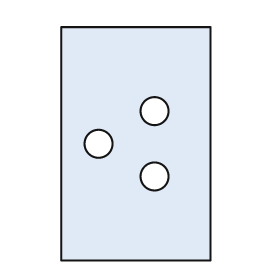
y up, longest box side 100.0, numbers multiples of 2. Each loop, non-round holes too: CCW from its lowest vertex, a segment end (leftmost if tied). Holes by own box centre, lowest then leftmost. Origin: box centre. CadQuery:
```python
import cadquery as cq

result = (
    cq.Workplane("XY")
    .moveTo(-32.0, -50.0)
    .lineTo(32.0, -50.0)
    .lineTo(32.0, 50.0)
    .lineTo(-32.0, 50.0)
    .close()
    .moveTo(8.0, -14.0)
    .circle(6.0)
    .moveTo(-16.0, 0.0)
    .circle(6.0)
    .moveTo(8.0, 14.0)
    .circle(6.0)
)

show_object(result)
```